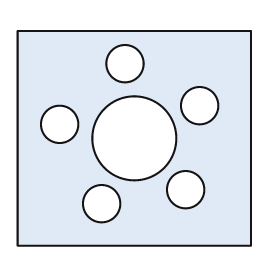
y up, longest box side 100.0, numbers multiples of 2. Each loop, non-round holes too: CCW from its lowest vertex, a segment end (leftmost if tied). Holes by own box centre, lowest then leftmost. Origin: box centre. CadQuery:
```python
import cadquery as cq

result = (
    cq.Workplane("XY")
    .moveTo(-50.0, -46.0)
    .lineTo(50.0, -46.0)
    .lineTo(50.0, 46.0)
    .lineTo(-50.0, 46.0)
    .close()
    .moveTo(-14.0, -28.0)
    .circle(8.0)
    .moveTo(22.0, -22.0)
    .circle(8.0)
    .moveTo(0.0, 0.0)
    .circle(18.0)
    .moveTo(-32.0, 6.0)
    .circle(8.0)
    .moveTo(28.0, 14.0)
    .circle(8.0)
    .moveTo(-4.0, 32.0)
    .circle(8.0)
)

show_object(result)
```